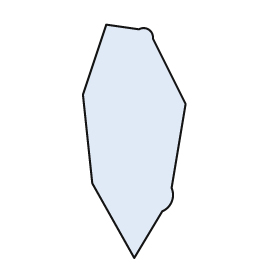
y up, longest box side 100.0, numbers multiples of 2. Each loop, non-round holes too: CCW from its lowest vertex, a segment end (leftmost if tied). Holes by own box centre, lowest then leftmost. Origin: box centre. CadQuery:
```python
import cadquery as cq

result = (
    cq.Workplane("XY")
    .moveTo(0.0, -50.0)
    .lineTo(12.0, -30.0)
    .threePointArc((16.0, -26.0), (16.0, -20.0))
    .lineTo(22.0, 16.0)
    .lineTo(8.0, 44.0)
    .threePointArc((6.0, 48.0), (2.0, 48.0))
    .lineTo(-12.0, 50.0)
    .lineTo(-22.0, 20.0)
    .lineTo(-18.0, -18.0)
    .close()
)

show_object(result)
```